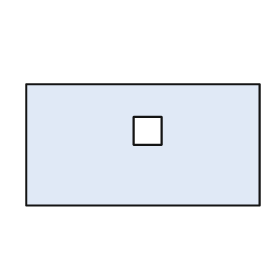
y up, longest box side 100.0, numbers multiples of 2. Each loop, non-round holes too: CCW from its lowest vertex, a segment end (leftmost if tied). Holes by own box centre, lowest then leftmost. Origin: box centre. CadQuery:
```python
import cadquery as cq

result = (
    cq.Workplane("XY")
    .moveTo(-50.0, -26.0)
    .lineTo(50.0, -26.0)
    .lineTo(50.0, 26.0)
    .lineTo(-50.0, 26.0)
    .close()
    .moveTo(-4.0, 0.0)
    .lineTo(8.0, 0.0)
    .lineTo(8.0, 12.0)
    .lineTo(-4.0, 12.0)
    .close()
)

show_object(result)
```